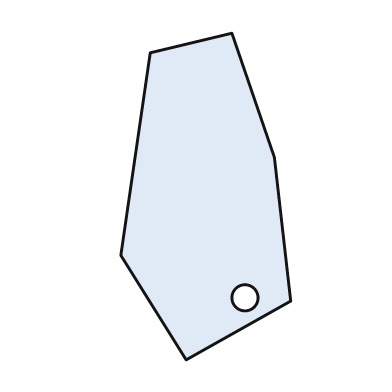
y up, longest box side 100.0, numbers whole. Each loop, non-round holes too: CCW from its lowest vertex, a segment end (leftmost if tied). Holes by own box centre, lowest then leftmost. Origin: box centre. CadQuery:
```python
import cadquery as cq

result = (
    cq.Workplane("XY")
    .moveTo(-6.0, -50.0)
    .lineTo(26.0, -32.0)
    .lineTo(21.0, 12.0)
    .lineTo(8.0, 50.0)
    .lineTo(-17.0, 44.0)
    .lineTo(-26.0, -18.0)
    .close()
    .moveTo(12.0, -31.0)
    .circle(4.0)
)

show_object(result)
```